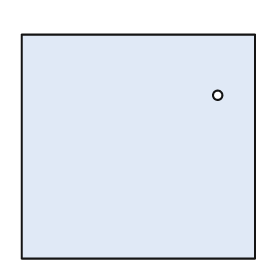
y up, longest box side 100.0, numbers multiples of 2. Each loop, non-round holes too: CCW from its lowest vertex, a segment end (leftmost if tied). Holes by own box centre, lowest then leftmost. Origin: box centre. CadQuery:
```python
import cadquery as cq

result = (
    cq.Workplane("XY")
    .moveTo(-50.0, -48.0)
    .lineTo(50.0, -48.0)
    .lineTo(50.0, 48.0)
    .lineTo(-50.0, 48.0)
    .close()
    .moveTo(34.0, 22.0)
    .circle(2.0)
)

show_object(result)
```